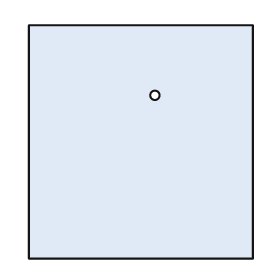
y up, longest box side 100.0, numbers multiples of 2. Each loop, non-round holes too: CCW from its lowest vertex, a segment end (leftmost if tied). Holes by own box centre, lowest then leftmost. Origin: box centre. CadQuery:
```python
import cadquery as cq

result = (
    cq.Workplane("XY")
    .moveTo(-48.0, -50.0)
    .lineTo(48.0, -50.0)
    .lineTo(48.0, 50.0)
    .lineTo(-48.0, 50.0)
    .close()
    .moveTo(6.0, 20.0)
    .circle(2.0)
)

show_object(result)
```